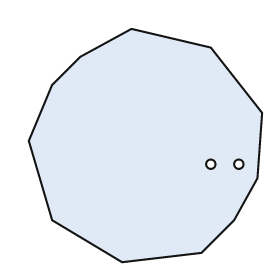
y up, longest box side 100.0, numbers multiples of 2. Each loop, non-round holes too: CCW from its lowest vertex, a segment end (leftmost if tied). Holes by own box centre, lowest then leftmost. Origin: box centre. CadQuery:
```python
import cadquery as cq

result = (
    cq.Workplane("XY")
    .moveTo(-10.0, -50.0)
    .lineTo(24.0, -46.0)
    .lineTo(38.0, -32.0)
    .lineTo(48.0, -14.0)
    .lineTo(50.0, 14.0)
    .lineTo(28.0, 42.0)
    .lineTo(-6.0, 50.0)
    .lineTo(-28.0, 38.0)
    .lineTo(-40.0, 26.0)
    .lineTo(-50.0, 2.0)
    .lineTo(-40.0, -32.0)
    .close()
    .moveTo(28.0, -8.0)
    .circle(2.0)
    .moveTo(40.0, -8.0)
    .circle(2.0)
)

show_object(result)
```